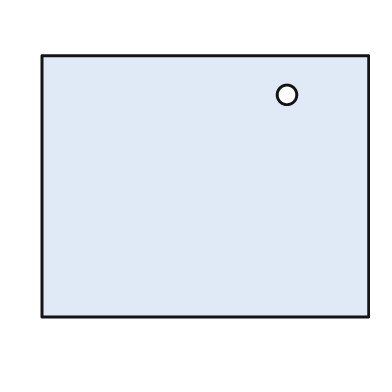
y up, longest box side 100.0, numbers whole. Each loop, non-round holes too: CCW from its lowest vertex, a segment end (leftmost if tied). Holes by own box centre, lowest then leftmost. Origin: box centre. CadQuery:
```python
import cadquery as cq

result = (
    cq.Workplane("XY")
    .moveTo(-50.0, -40.0)
    .lineTo(50.0, -40.0)
    .lineTo(50.0, 40.0)
    .lineTo(-50.0, 40.0)
    .close()
    .moveTo(25.0, 28.0)
    .circle(3.0)
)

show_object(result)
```